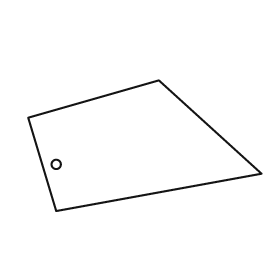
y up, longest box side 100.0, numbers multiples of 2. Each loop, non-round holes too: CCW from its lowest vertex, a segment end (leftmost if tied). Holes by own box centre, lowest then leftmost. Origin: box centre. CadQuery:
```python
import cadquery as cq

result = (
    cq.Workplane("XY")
    .moveTo(-38.0, -28.0)
    .lineTo(50.0, -12.0)
    .lineTo(6.0, 28.0)
    .lineTo(-50.0, 12.0)
    .close()
    .moveTo(-38.0, -8.0)
    .circle(2.0)
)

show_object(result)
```